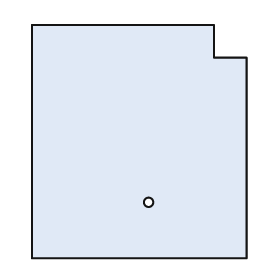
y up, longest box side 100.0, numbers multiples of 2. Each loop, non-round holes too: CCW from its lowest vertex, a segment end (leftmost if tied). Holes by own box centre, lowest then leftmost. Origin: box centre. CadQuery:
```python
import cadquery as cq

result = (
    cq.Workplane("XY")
    .moveTo(-46.0, -50.0)
    .lineTo(46.0, -50.0)
    .lineTo(46.0, 36.0)
    .lineTo(32.0, 36.0)
    .lineTo(32.0, 50.0)
    .lineTo(-46.0, 50.0)
    .close()
    .moveTo(4.0, -26.0)
    .circle(2.0)
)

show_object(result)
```